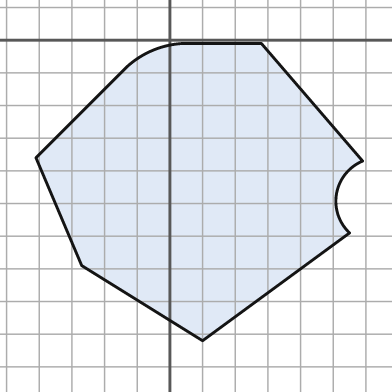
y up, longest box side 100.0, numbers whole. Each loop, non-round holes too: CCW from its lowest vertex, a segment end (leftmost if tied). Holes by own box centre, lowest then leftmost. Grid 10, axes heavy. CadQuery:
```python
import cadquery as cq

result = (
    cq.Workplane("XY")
    .moveTo(10.0, -92.0)
    .lineTo(55.0, -59.0)
    .threePointArc((51.0, -47.0), (59.0, -37.0))
    .lineTo(28.0, -1.0)
    .lineTo(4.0, -1.0)
    .threePointArc((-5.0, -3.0), (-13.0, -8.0))
    .lineTo(-41.0, -36.0)
    .lineTo(-27.0, -69.0)
    .close()
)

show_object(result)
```